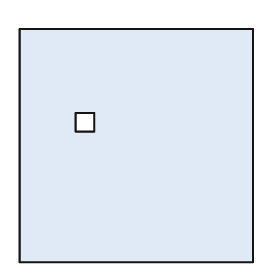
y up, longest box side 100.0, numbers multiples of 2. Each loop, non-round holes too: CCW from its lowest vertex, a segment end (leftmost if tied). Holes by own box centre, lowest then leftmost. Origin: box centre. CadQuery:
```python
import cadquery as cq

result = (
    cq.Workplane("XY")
    .moveTo(-50.0, -50.0)
    .lineTo(50.0, -50.0)
    .lineTo(50.0, 50.0)
    .lineTo(-50.0, 50.0)
    .close()
    .moveTo(-26.0, 6.0)
    .lineTo(-18.0, 6.0)
    .lineTo(-18.0, 14.0)
    .lineTo(-26.0, 14.0)
    .close()
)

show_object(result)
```